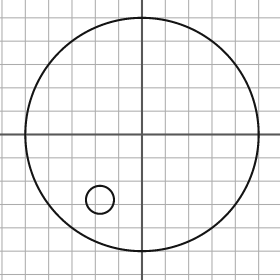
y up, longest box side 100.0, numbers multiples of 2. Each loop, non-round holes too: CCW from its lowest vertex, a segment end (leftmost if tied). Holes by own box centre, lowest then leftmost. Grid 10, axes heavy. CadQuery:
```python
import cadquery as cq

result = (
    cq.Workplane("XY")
    .moveTo(0.0, 0.0)
    .circle(50.0)
    .moveTo(-18.0, -28.0)
    .circle(6.0)
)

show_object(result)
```